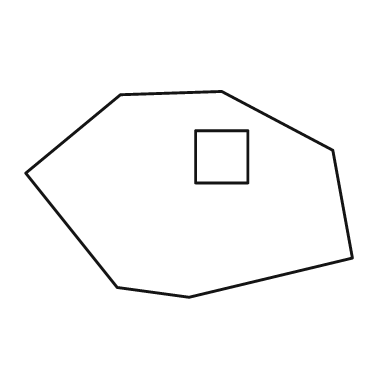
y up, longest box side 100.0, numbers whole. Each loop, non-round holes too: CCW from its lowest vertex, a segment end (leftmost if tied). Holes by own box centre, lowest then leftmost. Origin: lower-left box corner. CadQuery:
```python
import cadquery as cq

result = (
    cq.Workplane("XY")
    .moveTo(50.0, 0.0)
    .lineTo(100.0, 12.0)
    .lineTo(94.0, 45.0)
    .lineTo(60.0, 63.0)
    .lineTo(29.0, 62.0)
    .lineTo(0.0, 38.0)
    .lineTo(28.0, 3.0)
    .close()
    .moveTo(52.0, 35.0)
    .lineTo(68.0, 35.0)
    .lineTo(68.0, 51.0)
    .lineTo(52.0, 51.0)
    .close()
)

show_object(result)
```